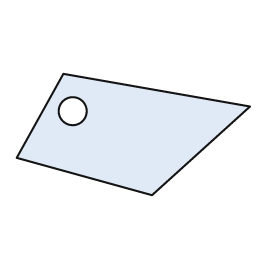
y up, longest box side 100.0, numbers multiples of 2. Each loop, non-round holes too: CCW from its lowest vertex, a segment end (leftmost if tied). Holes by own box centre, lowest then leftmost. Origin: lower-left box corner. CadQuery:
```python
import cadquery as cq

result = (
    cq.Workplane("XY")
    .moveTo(58.0, 0.0)
    .lineTo(100.0, 38.0)
    .lineTo(20.0, 52.0)
    .lineTo(0.0, 16.0)
    .close()
    .moveTo(24.0, 36.0)
    .circle(6.0)
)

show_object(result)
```